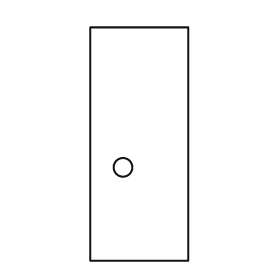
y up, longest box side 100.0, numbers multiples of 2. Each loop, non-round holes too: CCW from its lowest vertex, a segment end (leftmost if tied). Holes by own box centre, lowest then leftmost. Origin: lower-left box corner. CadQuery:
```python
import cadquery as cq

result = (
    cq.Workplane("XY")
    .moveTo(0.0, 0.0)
    .lineTo(42.0, 0.0)
    .lineTo(42.0, 100.0)
    .lineTo(0.0, 100.0)
    .close()
    .moveTo(14.0, 40.0)
    .circle(4.0)
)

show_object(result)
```